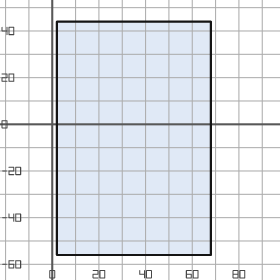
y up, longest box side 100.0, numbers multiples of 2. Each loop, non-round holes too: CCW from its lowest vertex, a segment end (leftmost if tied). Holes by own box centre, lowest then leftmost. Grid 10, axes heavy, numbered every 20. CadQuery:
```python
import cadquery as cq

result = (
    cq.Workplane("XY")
    .moveTo(2.0, -56.0)
    .lineTo(68.0, -56.0)
    .lineTo(68.0, 44.0)
    .lineTo(2.0, 44.0)
    .close()
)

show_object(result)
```